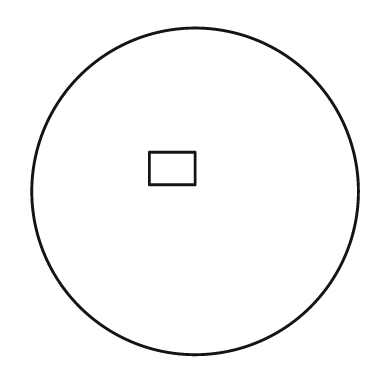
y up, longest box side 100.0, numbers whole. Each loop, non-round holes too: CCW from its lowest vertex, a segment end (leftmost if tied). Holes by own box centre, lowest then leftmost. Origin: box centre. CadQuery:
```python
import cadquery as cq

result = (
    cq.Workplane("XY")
    .moveTo(0.0, 0.0)
    .circle(50.0)
    .moveTo(-14.0, 2.0)
    .lineTo(0.0, 2.0)
    .lineTo(0.0, 12.0)
    .lineTo(-14.0, 12.0)
    .close()
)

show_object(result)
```